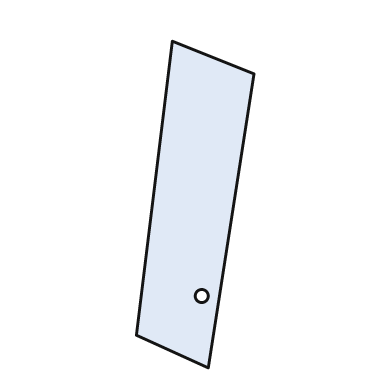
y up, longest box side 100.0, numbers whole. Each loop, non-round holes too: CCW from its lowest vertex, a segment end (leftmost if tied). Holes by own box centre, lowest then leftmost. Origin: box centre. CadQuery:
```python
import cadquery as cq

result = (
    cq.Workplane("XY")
    .moveTo(4.0, -50.0)
    .lineTo(18.0, 40.0)
    .lineTo(-7.0, 50.0)
    .lineTo(-18.0, -40.0)
    .close()
    .moveTo(2.0, -28.0)
    .circle(2.0)
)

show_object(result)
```